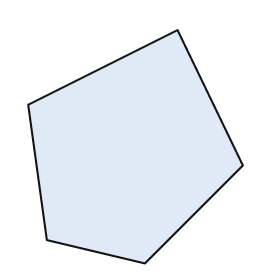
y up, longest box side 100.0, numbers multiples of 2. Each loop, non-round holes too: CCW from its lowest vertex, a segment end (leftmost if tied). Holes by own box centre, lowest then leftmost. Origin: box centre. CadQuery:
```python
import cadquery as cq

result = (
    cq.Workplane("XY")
    .moveTo(4.0, -50.0)
    .lineTo(46.0, -8.0)
    .lineTo(18.0, 50.0)
    .lineTo(-46.0, 18.0)
    .lineTo(-38.0, -40.0)
    .close()
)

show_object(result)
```